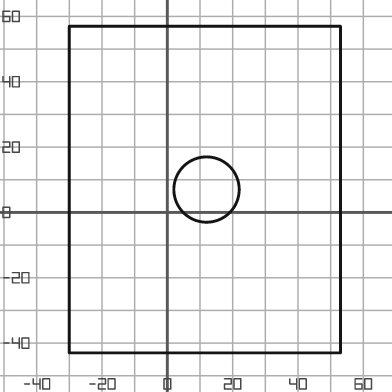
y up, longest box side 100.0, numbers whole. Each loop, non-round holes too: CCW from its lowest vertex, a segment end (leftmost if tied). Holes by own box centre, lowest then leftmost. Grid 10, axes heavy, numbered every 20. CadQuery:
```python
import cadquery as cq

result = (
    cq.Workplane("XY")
    .moveTo(-30.0, -43.0)
    .lineTo(53.0, -43.0)
    .lineTo(53.0, 57.0)
    .lineTo(-30.0, 57.0)
    .close()
    .moveTo(12.0, 7.0)
    .circle(10.0)
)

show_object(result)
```